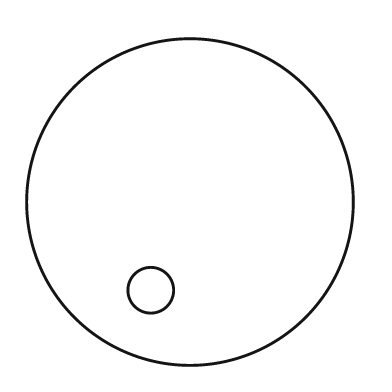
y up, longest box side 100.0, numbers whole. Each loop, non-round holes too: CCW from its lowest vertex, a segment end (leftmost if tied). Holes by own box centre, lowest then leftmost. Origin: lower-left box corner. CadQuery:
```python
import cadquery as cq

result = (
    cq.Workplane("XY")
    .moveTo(50.0, 50.0)
    .circle(50.0)
    .moveTo(38.0, 23.0)
    .circle(7.0)
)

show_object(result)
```